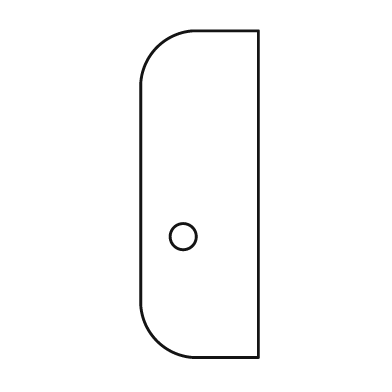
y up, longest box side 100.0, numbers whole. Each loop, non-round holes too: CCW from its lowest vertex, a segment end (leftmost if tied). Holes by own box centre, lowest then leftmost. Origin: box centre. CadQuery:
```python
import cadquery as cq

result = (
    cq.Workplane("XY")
    .moveTo(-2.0, -50.0)
    .lineTo(18.0, -50.0)
    .lineTo(18.0, 50.0)
    .lineTo(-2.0, 50.0)
    .threePointArc((-13.0, 45.0), (-18.0, 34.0))
    .lineTo(-18.0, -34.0)
    .threePointArc((-13.0, -45.0), (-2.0, -50.0))
    .close()
    .moveTo(-5.0, -13.0)
    .circle(4.0)
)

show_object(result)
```